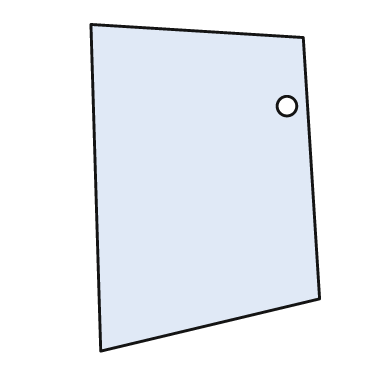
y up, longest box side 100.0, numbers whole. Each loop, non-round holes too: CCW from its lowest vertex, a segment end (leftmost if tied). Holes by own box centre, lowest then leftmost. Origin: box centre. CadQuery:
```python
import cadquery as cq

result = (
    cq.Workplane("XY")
    .moveTo(-32.0, -50.0)
    .lineTo(35.0, -34.0)
    .lineTo(30.0, 46.0)
    .lineTo(-35.0, 50.0)
    .close()
    .moveTo(25.0, 25.0)
    .circle(3.0)
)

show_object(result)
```